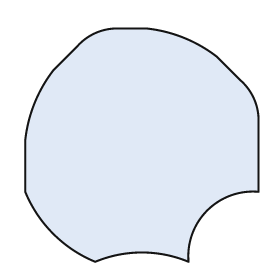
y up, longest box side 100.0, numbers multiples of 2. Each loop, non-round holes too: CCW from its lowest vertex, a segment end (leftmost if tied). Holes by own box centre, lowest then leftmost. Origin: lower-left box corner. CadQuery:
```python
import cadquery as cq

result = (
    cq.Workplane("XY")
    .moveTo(30.0, 0.0)
    .threePointArc((50.0, 4.0), (70.0, 0.0))
    .threePointArc((78.0, 22.0), (100.0, 30.0))
    .lineTo(100.0, 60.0)
    .threePointArc((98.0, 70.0), (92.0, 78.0))
    .lineTo(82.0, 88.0)
    .threePointArc((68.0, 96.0), (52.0, 100.0))
    .lineTo(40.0, 100.0)
    .threePointArc((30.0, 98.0), (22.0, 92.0))
    .lineTo(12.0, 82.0)
    .threePointArc((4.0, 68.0), (0.0, 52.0))
    .lineTo(0.0, 30.0)
    .threePointArc((12.0, 12.0), (30.0, 0.0))
    .close()
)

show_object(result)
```